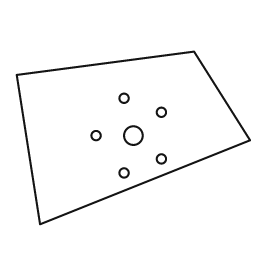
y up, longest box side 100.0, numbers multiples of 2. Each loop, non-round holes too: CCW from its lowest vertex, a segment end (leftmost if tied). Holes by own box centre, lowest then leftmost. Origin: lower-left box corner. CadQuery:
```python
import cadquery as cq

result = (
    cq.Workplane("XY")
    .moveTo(10.0, 0.0)
    .lineTo(100.0, 36.0)
    .lineTo(76.0, 74.0)
    .lineTo(0.0, 64.0)
    .close()
    .moveTo(46.0, 22.0)
    .circle(2.0)
    .moveTo(62.0, 28.0)
    .circle(2.0)
    .moveTo(34.0, 38.0)
    .circle(2.0)
    .moveTo(50.0, 38.0)
    .circle(4.0)
    .moveTo(62.0, 48.0)
    .circle(2.0)
    .moveTo(46.0, 54.0)
    .circle(2.0)
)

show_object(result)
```